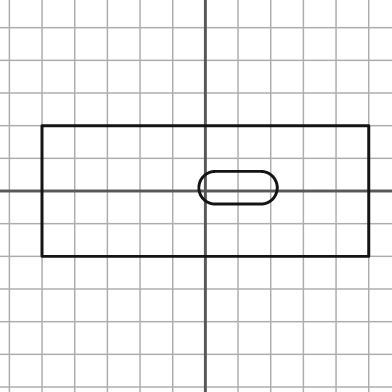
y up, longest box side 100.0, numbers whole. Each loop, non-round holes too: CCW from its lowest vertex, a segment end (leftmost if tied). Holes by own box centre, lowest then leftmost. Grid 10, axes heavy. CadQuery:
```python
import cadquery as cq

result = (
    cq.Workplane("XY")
    .moveTo(-50.0, -20.0)
    .lineTo(50.0, -20.0)
    .lineTo(50.0, 20.0)
    .lineTo(-50.0, 20.0)
    .close()
    .moveTo(3.0, -4.0)
    .lineTo(17.0, -4.0)
    .threePointArc((22.0, 1.0), (17.0, 6.0))
    .lineTo(3.0, 6.0)
    .threePointArc((-2.0, 1.0), (3.0, -4.0))
    .close()
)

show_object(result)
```